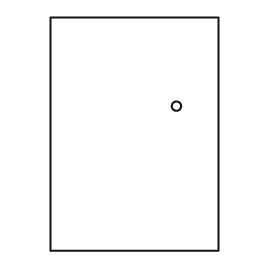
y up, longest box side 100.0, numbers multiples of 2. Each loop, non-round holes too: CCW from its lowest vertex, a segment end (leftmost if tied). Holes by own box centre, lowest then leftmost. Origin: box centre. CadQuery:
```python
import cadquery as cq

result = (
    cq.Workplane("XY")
    .moveTo(-36.0, -50.0)
    .lineTo(36.0, -50.0)
    .lineTo(36.0, 50.0)
    .lineTo(-36.0, 50.0)
    .close()
    .moveTo(18.0, 12.0)
    .circle(2.0)
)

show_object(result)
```